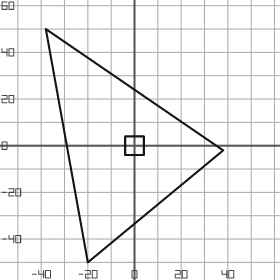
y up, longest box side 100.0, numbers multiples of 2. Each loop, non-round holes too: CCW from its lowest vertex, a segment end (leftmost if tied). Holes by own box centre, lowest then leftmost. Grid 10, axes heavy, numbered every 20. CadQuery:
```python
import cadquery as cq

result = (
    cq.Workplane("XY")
    .moveTo(-20.0, -50.0)
    .lineTo(38.0, -2.0)
    .lineTo(-38.0, 50.0)
    .close()
    .moveTo(-4.0, -4.0)
    .lineTo(4.0, -4.0)
    .lineTo(4.0, 4.0)
    .lineTo(-4.0, 4.0)
    .close()
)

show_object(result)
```